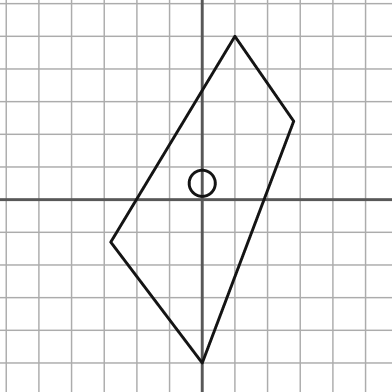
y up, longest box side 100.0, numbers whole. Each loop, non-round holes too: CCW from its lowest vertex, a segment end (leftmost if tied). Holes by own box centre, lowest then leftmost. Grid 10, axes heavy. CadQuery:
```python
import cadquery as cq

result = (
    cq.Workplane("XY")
    .moveTo(0.0, -50.0)
    .lineTo(28.0, 24.0)
    .lineTo(10.0, 50.0)
    .lineTo(-28.0, -13.0)
    .close()
    .moveTo(0.0, 5.0)
    .circle(4.0)
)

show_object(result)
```